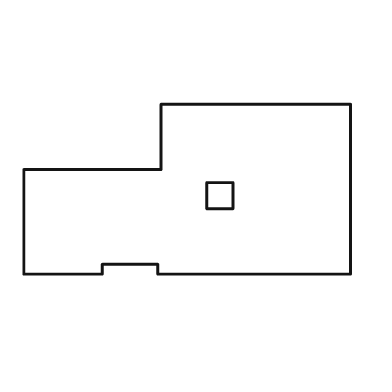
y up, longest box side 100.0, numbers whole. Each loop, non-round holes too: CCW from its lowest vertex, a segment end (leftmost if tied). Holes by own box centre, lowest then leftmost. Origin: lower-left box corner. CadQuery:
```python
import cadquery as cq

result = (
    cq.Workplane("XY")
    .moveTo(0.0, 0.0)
    .lineTo(24.0, 0.0)
    .lineTo(24.0, 3.0)
    .lineTo(41.0, 3.0)
    .lineTo(41.0, 0.0)
    .lineTo(100.0, 0.0)
    .lineTo(100.0, 52.0)
    .lineTo(42.0, 52.0)
    .lineTo(42.0, 32.0)
    .lineTo(0.0, 32.0)
    .close()
    .moveTo(56.0, 20.0)
    .lineTo(64.0, 20.0)
    .lineTo(64.0, 28.0)
    .lineTo(56.0, 28.0)
    .close()
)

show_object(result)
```